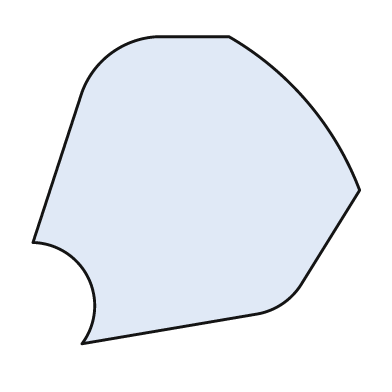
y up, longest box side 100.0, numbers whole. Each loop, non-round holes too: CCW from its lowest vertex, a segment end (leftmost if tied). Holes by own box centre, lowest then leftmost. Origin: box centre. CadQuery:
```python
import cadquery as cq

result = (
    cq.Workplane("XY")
    .moveTo(-35.0, -47.0)
    .lineTo(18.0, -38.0)
    .threePointArc((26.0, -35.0), (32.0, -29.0))
    .lineTo(50.0, 0.0)
    .threePointArc((34.0, 27.0), (10.0, 47.0))
    .lineTo(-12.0, 47.0)
    .threePointArc((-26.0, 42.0), (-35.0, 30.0))
    .lineTo(-50.0, -16.0)
    .threePointArc((-33.0, -27.0), (-35.0, -47.0))
    .close()
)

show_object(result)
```